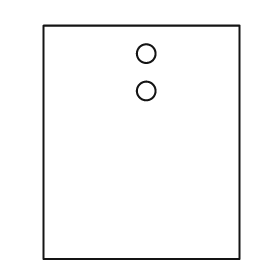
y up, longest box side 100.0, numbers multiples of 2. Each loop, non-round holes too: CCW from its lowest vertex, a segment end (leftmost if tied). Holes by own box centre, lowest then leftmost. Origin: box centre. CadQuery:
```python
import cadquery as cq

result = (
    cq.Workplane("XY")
    .moveTo(-42.0, -50.0)
    .lineTo(42.0, -50.0)
    .lineTo(42.0, 50.0)
    .lineTo(-42.0, 50.0)
    .close()
    .moveTo(2.0, 22.0)
    .circle(4.0)
    .moveTo(2.0, 38.0)
    .circle(4.0)
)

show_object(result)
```